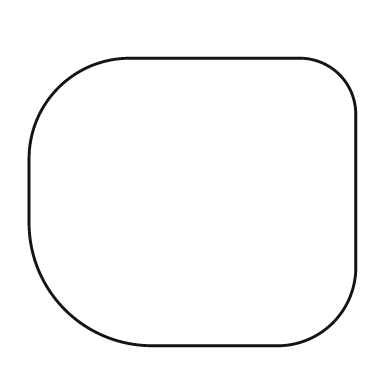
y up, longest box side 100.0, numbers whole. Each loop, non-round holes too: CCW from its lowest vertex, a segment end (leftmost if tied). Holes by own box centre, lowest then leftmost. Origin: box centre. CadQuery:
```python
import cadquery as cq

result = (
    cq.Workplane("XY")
    .moveTo(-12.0, -44.0)
    .lineTo(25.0, -44.0)
    .threePointArc((43.0, -37.0), (50.0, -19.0))
    .lineTo(50.0, 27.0)
    .threePointArc((45.0, 39.0), (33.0, 44.0))
    .lineTo(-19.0, 44.0)
    .threePointArc((-41.0, 35.0), (-50.0, 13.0))
    .lineTo(-50.0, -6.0)
    .threePointArc((-39.0, -33.0), (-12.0, -44.0))
    .close()
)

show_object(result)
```